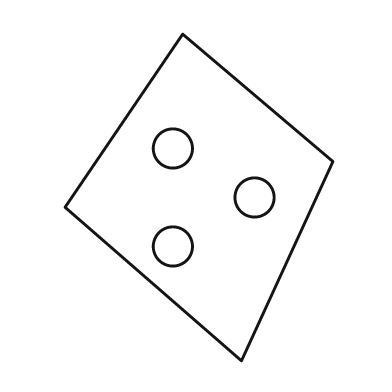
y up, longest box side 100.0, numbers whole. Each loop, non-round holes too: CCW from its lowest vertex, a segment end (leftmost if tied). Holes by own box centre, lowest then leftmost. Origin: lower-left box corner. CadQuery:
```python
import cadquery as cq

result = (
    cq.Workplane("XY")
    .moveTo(54.0, 0.0)
    .lineTo(82.0, 61.0)
    .lineTo(36.0, 100.0)
    .lineTo(0.0, 47.0)
    .close()
    .moveTo(33.0, 35.0)
    .circle(6.0)
    .moveTo(58.0, 50.0)
    .circle(6.0)
    .moveTo(33.0, 65.0)
    .circle(6.0)
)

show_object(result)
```